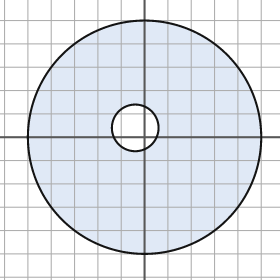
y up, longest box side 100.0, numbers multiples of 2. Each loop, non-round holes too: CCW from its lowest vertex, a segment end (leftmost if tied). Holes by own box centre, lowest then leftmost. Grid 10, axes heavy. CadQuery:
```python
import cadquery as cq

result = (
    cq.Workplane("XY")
    .moveTo(0.0, 0.0)
    .circle(50.0)
    .moveTo(-4.0, 4.0)
    .circle(10.0)
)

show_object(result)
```